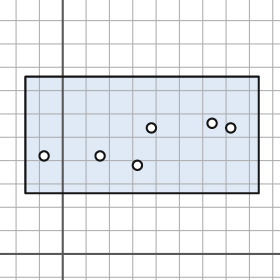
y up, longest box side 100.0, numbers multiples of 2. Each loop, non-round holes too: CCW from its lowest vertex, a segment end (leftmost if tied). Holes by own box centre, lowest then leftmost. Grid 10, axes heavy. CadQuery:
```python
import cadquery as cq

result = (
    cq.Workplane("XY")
    .moveTo(-16.0, 26.0)
    .lineTo(84.0, 26.0)
    .lineTo(84.0, 76.0)
    .lineTo(-16.0, 76.0)
    .close()
    .moveTo(32.0, 38.0)
    .circle(2.0)
    .moveTo(-8.0, 42.0)
    .circle(2.0)
    .moveTo(16.0, 42.0)
    .circle(2.0)
    .moveTo(38.0, 54.0)
    .circle(2.0)
    .moveTo(72.0, 54.0)
    .circle(2.0)
    .moveTo(64.0, 56.0)
    .circle(2.0)
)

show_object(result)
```